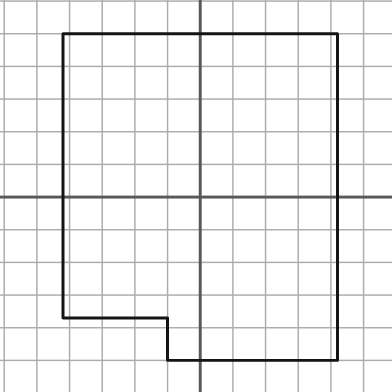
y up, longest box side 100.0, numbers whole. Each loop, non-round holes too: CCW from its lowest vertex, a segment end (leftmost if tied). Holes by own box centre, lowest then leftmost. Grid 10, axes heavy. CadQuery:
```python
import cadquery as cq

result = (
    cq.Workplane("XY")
    .moveTo(-10.0, -50.0)
    .lineTo(42.0, -50.0)
    .lineTo(42.0, 50.0)
    .lineTo(-42.0, 50.0)
    .lineTo(-42.0, -37.0)
    .lineTo(-10.0, -37.0)
    .close()
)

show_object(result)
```